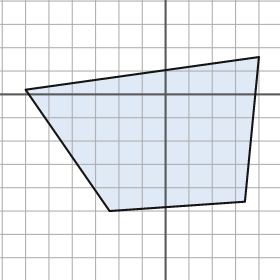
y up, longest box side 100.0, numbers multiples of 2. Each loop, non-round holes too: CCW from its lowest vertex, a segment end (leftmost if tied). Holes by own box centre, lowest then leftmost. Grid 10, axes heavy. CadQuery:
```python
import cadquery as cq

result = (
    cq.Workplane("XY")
    .moveTo(-24.0, -50.0)
    .lineTo(34.0, -46.0)
    .lineTo(40.0, 16.0)
    .lineTo(-60.0, 2.0)
    .close()
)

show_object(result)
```